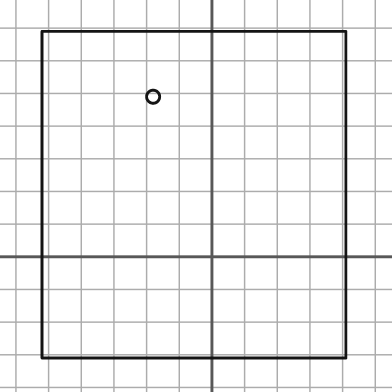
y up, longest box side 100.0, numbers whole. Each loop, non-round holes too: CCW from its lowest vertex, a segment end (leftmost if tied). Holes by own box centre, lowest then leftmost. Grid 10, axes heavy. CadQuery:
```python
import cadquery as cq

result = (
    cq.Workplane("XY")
    .moveTo(-52.0, -31.0)
    .lineTo(41.0, -31.0)
    .lineTo(41.0, 69.0)
    .lineTo(-52.0, 69.0)
    .close()
    .moveTo(-18.0, 49.0)
    .circle(2.0)
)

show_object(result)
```